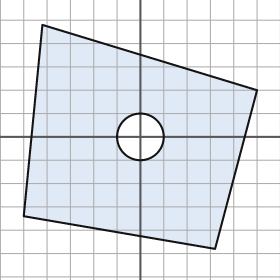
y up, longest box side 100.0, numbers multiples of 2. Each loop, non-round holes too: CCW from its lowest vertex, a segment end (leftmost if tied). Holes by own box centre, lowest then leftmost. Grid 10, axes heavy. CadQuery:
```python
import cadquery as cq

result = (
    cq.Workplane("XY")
    .moveTo(32.0, -48.0)
    .lineTo(50.0, 20.0)
    .lineTo(-42.0, 48.0)
    .lineTo(-50.0, -34.0)
    .close()
    .moveTo(0.0, 0.0)
    .circle(10.0)
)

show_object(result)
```